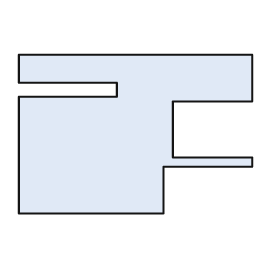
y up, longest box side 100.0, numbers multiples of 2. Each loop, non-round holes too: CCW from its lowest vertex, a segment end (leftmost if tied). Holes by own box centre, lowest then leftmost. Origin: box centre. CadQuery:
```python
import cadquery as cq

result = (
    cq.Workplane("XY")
    .moveTo(-50.0, -34.0)
    .lineTo(12.0, -34.0)
    .lineTo(12.0, -14.0)
    .lineTo(50.0, -14.0)
    .lineTo(50.0, -10.0)
    .lineTo(16.0, -10.0)
    .lineTo(16.0, 14.0)
    .lineTo(50.0, 14.0)
    .lineTo(50.0, 34.0)
    .lineTo(-50.0, 34.0)
    .lineTo(-50.0, 22.0)
    .lineTo(-8.0, 22.0)
    .lineTo(-8.0, 16.0)
    .lineTo(-50.0, 16.0)
    .close()
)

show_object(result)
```